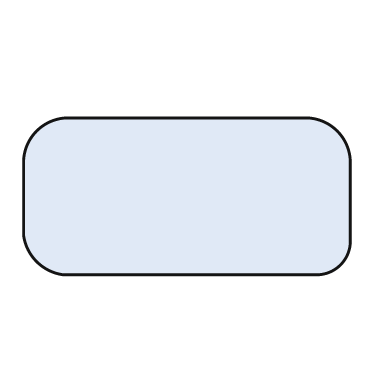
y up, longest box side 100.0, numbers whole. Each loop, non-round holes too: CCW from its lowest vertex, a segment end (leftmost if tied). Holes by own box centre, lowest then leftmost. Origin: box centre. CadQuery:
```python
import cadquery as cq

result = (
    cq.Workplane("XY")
    .moveTo(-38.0, -24.0)
    .lineTo(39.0, -24.0)
    .threePointArc((47.0, -21.0), (50.0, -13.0))
    .lineTo(50.0, 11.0)
    .threePointArc((46.0, 20.0), (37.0, 24.0))
    .lineTo(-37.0, 24.0)
    .threePointArc((-46.0, 20.0), (-50.0, 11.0))
    .lineTo(-50.0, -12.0)
    .threePointArc((-46.0, -20.0), (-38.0, -24.0))
    .close()
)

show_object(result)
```